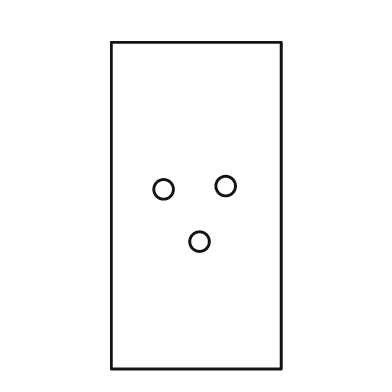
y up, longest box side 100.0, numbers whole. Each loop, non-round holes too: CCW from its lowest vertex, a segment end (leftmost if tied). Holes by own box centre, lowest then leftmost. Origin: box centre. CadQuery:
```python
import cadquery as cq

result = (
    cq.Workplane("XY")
    .moveTo(-26.0, -50.0)
    .lineTo(26.0, -50.0)
    .lineTo(26.0, 50.0)
    .lineTo(-26.0, 50.0)
    .close()
    .moveTo(1.0, -11.0)
    .circle(3.0)
    .moveTo(-10.0, 5.0)
    .circle(3.0)
    .moveTo(9.0, 6.0)
    .circle(3.0)
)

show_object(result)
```